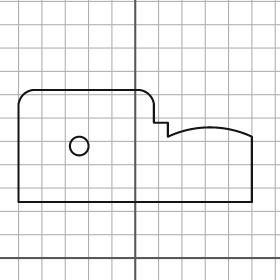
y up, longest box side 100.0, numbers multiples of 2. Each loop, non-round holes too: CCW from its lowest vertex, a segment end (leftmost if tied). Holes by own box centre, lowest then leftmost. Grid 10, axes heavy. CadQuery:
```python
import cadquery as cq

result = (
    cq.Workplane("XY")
    .moveTo(-50.0, 24.0)
    .lineTo(50.0, 24.0)
    .lineTo(50.0, 52.0)
    .threePointArc((32.0, 56.0), (14.0, 52.0))
    .lineTo(14.0, 58.0)
    .lineTo(8.0, 58.0)
    .lineTo(8.0, 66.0)
    .threePointArc((6.0, 70.0), (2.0, 72.0))
    .lineTo(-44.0, 72.0)
    .threePointArc((-48.0, 70.0), (-50.0, 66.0))
    .close()
    .moveTo(-24.0, 48.0)
    .circle(4.0)
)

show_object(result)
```